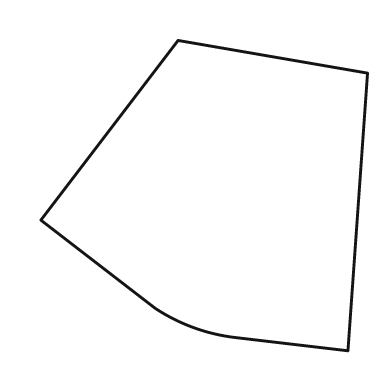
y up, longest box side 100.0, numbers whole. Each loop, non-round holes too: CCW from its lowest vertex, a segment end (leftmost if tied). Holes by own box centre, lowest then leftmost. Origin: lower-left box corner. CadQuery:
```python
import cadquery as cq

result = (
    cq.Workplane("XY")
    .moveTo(94.0, 0.0)
    .lineTo(100.0, 85.0)
    .lineTo(42.0, 95.0)
    .lineTo(0.0, 40.0)
    .lineTo(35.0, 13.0)
    .threePointArc((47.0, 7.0), (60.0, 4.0))
    .close()
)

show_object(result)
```